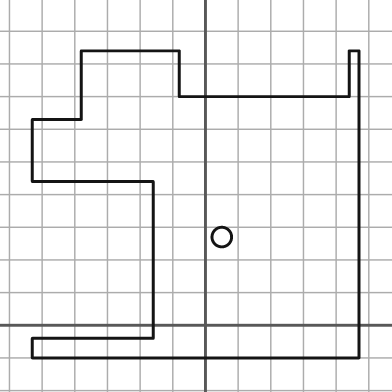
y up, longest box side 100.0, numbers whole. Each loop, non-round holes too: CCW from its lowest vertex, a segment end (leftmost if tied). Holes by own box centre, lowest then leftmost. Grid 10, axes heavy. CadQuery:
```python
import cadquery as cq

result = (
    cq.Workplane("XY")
    .moveTo(-53.0, -10.0)
    .lineTo(47.0, -10.0)
    .lineTo(47.0, 84.0)
    .lineTo(44.0, 84.0)
    .lineTo(44.0, 70.0)
    .lineTo(-8.0, 70.0)
    .lineTo(-8.0, 84.0)
    .lineTo(-38.0, 84.0)
    .lineTo(-38.0, 63.0)
    .lineTo(-53.0, 63.0)
    .lineTo(-53.0, 44.0)
    .lineTo(-16.0, 44.0)
    .lineTo(-16.0, -4.0)
    .lineTo(-53.0, -4.0)
    .close()
    .moveTo(5.0, 27.0)
    .circle(3.0)
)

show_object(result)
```